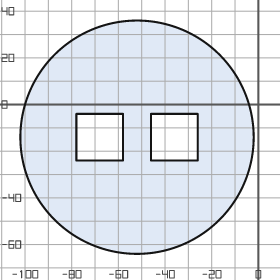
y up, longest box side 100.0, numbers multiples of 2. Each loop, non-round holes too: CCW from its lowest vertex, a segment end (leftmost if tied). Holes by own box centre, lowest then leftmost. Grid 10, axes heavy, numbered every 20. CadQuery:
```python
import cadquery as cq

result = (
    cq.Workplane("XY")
    .moveTo(-52.0, -14.0)
    .circle(50.0)
    .moveTo(-78.0, -24.0)
    .lineTo(-58.0, -24.0)
    .lineTo(-58.0, -4.0)
    .lineTo(-78.0, -4.0)
    .close()
    .moveTo(-46.0, -24.0)
    .lineTo(-26.0, -24.0)
    .lineTo(-26.0, -4.0)
    .lineTo(-46.0, -4.0)
    .close()
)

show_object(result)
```